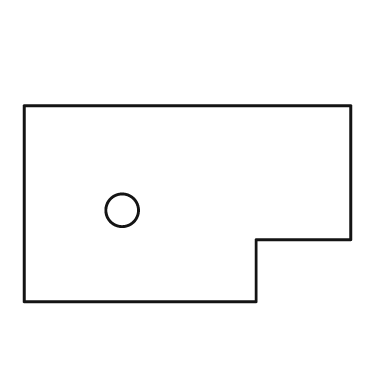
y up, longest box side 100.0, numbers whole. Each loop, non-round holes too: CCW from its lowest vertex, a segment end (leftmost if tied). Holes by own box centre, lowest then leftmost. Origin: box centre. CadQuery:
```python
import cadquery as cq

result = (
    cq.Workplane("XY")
    .moveTo(-50.0, -30.0)
    .lineTo(21.0, -30.0)
    .lineTo(21.0, -11.0)
    .lineTo(50.0, -11.0)
    .lineTo(50.0, 30.0)
    .lineTo(-50.0, 30.0)
    .close()
    .moveTo(-20.0, -2.0)
    .circle(5.0)
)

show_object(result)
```